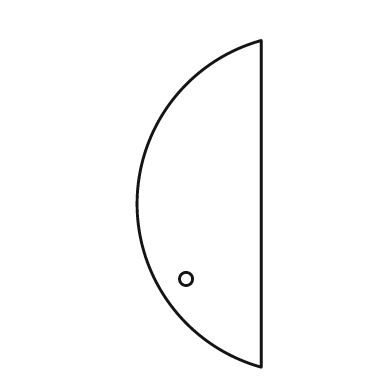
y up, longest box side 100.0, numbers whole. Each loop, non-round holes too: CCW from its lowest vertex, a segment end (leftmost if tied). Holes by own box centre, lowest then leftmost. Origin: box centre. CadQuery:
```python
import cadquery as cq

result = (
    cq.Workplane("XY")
    .moveTo(19.0, -50.0)
    .lineTo(19.0, 50.0)
    .threePointArc((-19.0, 0.0), (19.0, -50.0))
    .close()
    .moveTo(-4.0, -23.0)
    .circle(2.0)
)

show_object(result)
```